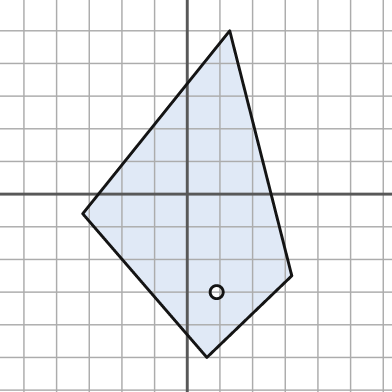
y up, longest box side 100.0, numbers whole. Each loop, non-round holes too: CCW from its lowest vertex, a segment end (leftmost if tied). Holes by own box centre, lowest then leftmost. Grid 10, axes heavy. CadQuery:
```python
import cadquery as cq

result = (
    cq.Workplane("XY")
    .moveTo(6.0, -50.0)
    .lineTo(32.0, -25.0)
    .lineTo(13.0, 50.0)
    .lineTo(-32.0, -6.0)
    .close()
    .moveTo(9.0, -30.0)
    .circle(2.0)
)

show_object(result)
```